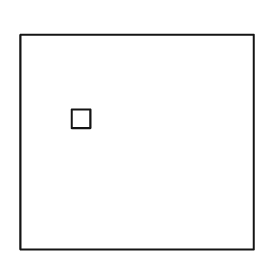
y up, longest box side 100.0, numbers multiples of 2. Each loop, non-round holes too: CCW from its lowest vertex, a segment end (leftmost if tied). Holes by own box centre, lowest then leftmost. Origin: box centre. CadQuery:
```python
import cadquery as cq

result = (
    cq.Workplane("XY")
    .moveTo(-50.0, -46.0)
    .lineTo(50.0, -46.0)
    .lineTo(50.0, 46.0)
    .lineTo(-50.0, 46.0)
    .close()
    .moveTo(-28.0, 6.0)
    .lineTo(-20.0, 6.0)
    .lineTo(-20.0, 14.0)
    .lineTo(-28.0, 14.0)
    .close()
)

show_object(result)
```